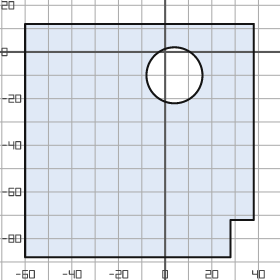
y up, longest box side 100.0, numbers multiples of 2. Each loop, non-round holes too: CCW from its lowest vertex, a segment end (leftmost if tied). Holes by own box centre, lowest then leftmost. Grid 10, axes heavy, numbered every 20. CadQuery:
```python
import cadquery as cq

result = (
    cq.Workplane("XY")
    .moveTo(-60.0, -88.0)
    .lineTo(28.0, -88.0)
    .lineTo(28.0, -72.0)
    .lineTo(38.0, -72.0)
    .lineTo(38.0, 12.0)
    .lineTo(-60.0, 12.0)
    .close()
    .moveTo(4.0, -10.0)
    .circle(12.0)
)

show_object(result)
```